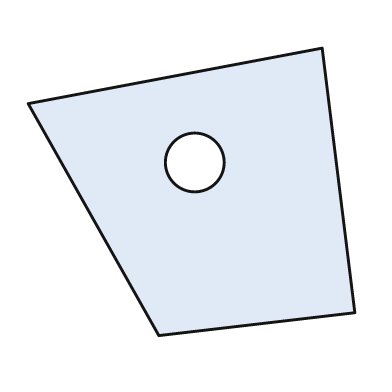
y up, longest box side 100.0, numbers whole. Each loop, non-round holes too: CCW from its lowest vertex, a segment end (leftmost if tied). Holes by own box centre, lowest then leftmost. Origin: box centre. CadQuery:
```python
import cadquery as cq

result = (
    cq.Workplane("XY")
    .moveTo(-10.0, -44.0)
    .lineTo(50.0, -37.0)
    .lineTo(40.0, 44.0)
    .lineTo(-50.0, 27.0)
    .close()
    .moveTo(1.0, 9.0)
    .circle(9.0)
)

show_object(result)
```